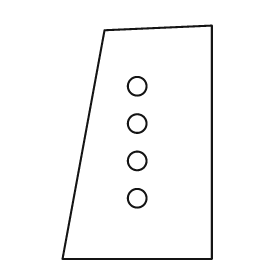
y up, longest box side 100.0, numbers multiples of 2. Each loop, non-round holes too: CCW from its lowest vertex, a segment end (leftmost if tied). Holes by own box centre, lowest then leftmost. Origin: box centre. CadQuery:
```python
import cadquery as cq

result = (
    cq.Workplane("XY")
    .moveTo(-32.0, -50.0)
    .lineTo(32.0, -50.0)
    .lineTo(32.0, 50.0)
    .lineTo(-14.0, 48.0)
    .close()
    .moveTo(0.0, -24.0)
    .circle(4.0)
    .moveTo(0.0, -8.0)
    .circle(4.0)
    .moveTo(0.0, 8.0)
    .circle(4.0)
    .moveTo(0.0, 24.0)
    .circle(4.0)
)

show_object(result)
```